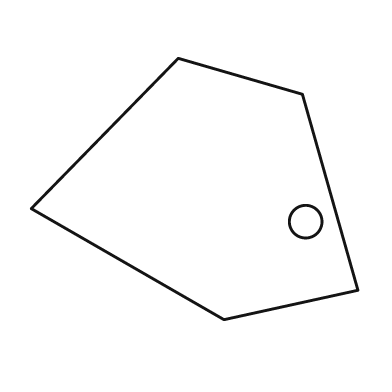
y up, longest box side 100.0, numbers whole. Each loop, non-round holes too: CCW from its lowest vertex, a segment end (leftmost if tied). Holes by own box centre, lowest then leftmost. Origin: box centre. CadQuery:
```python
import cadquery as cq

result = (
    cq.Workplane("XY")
    .moveTo(9.0, -40.0)
    .lineTo(50.0, -31.0)
    .lineTo(33.0, 29.0)
    .lineTo(-5.0, 40.0)
    .lineTo(-50.0, -6.0)
    .close()
    .moveTo(34.0, -10.0)
    .circle(5.0)
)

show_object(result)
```